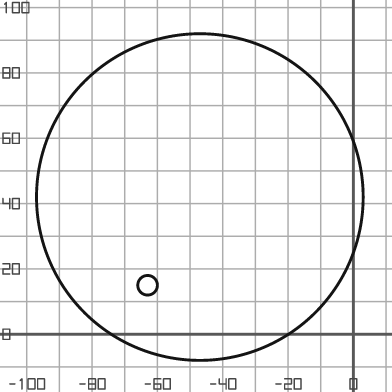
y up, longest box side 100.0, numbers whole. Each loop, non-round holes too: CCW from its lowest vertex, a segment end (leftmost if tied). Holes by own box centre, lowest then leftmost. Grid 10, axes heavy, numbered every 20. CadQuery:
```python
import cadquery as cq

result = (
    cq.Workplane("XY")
    .moveTo(-47.0, 42.0)
    .circle(50.0)
    .moveTo(-63.0, 15.0)
    .circle(3.0)
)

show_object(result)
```